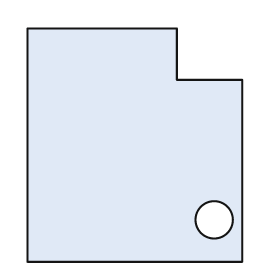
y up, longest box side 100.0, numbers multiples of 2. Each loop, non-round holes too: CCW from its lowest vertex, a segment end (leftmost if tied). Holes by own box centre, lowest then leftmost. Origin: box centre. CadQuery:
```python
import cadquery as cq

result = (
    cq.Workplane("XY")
    .moveTo(-46.0, -50.0)
    .lineTo(46.0, -50.0)
    .lineTo(46.0, 28.0)
    .lineTo(18.0, 28.0)
    .lineTo(18.0, 50.0)
    .lineTo(-46.0, 50.0)
    .close()
    .moveTo(34.0, -32.0)
    .circle(8.0)
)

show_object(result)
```